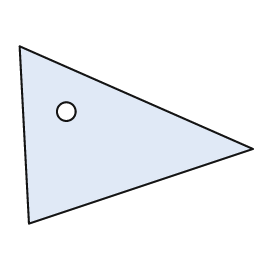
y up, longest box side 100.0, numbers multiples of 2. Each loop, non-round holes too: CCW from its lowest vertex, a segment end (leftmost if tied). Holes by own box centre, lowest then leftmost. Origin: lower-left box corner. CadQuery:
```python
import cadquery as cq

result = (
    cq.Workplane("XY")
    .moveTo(4.0, 0.0)
    .lineTo(100.0, 32.0)
    .lineTo(0.0, 76.0)
    .close()
    .moveTo(20.0, 48.0)
    .circle(4.0)
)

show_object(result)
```